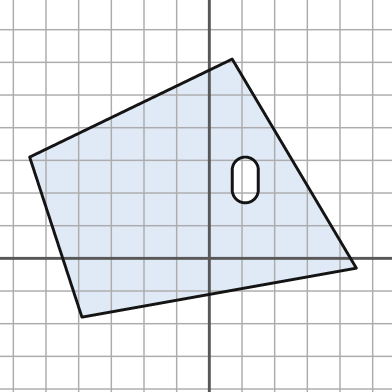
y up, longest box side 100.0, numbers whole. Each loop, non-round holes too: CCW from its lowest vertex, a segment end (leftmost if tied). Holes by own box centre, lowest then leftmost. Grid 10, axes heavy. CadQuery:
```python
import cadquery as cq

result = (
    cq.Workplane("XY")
    .moveTo(-39.0, -18.0)
    .lineTo(45.0, -3.0)
    .lineTo(7.0, 61.0)
    .lineTo(-55.0, 31.0)
    .close()
    .moveTo(7.0, 21.0)
    .threePointArc((11.0, 17.0), (15.0, 21.0))
    .lineTo(15.0, 27.0)
    .threePointArc((11.0, 31.0), (7.0, 27.0))
    .close()
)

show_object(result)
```